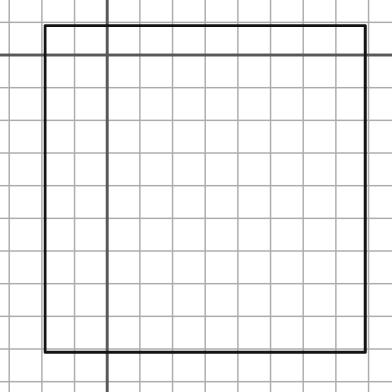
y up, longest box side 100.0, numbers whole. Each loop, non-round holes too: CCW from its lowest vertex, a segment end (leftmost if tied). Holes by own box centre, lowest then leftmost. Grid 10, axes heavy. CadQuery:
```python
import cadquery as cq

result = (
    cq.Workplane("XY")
    .moveTo(-19.0, -91.0)
    .lineTo(79.0, -91.0)
    .lineTo(79.0, 9.0)
    .lineTo(-19.0, 9.0)
    .close()
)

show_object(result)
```